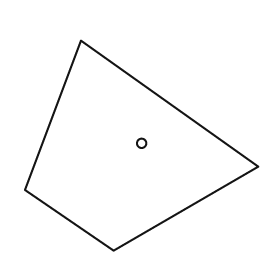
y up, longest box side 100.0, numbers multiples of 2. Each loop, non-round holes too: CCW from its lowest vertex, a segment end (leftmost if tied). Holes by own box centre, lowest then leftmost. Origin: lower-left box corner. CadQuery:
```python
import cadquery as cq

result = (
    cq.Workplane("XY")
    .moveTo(38.0, 0.0)
    .lineTo(100.0, 36.0)
    .lineTo(24.0, 90.0)
    .lineTo(0.0, 26.0)
    .close()
    .moveTo(50.0, 46.0)
    .circle(2.0)
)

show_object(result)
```